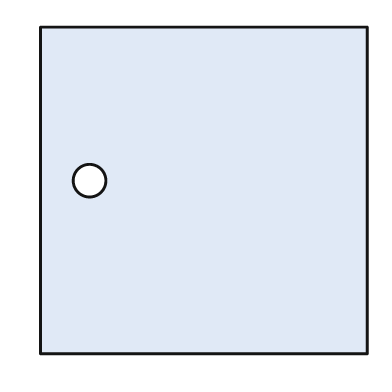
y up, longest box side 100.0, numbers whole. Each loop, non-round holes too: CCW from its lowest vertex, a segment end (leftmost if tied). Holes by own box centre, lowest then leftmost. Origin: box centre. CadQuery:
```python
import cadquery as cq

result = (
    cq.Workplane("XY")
    .moveTo(-50.0, -50.0)
    .lineTo(50.0, -50.0)
    .lineTo(50.0, 50.0)
    .lineTo(-50.0, 50.0)
    .close()
    .moveTo(-35.0, 3.0)
    .circle(5.0)
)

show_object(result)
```